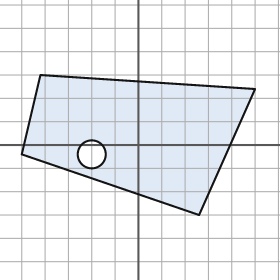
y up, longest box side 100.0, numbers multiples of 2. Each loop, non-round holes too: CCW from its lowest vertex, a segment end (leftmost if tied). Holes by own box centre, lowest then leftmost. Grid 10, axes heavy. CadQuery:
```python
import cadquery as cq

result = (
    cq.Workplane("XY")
    .moveTo(26.0, -30.0)
    .lineTo(50.0, 24.0)
    .lineTo(-42.0, 30.0)
    .lineTo(-50.0, -4.0)
    .close()
    .moveTo(-20.0, -4.0)
    .circle(6.0)
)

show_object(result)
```